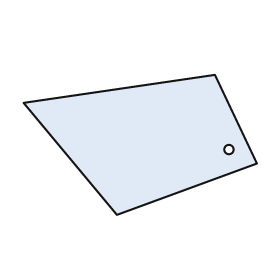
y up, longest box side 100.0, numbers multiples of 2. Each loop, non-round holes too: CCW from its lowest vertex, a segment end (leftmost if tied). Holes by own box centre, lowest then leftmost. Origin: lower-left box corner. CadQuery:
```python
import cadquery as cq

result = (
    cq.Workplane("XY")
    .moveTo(40.0, 0.0)
    .lineTo(100.0, 22.0)
    .lineTo(82.0, 60.0)
    .lineTo(0.0, 48.0)
    .close()
    .moveTo(88.0, 28.0)
    .circle(2.0)
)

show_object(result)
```